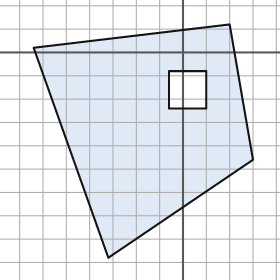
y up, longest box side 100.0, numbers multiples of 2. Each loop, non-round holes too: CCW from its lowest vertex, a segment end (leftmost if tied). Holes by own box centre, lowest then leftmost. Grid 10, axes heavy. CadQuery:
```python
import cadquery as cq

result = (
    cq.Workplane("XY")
    .moveTo(-32.0, -88.0)
    .lineTo(30.0, -46.0)
    .lineTo(20.0, 12.0)
    .lineTo(-64.0, 2.0)
    .close()
    .moveTo(-6.0, -24.0)
    .lineTo(10.0, -24.0)
    .lineTo(10.0, -8.0)
    .lineTo(-6.0, -8.0)
    .close()
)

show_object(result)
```